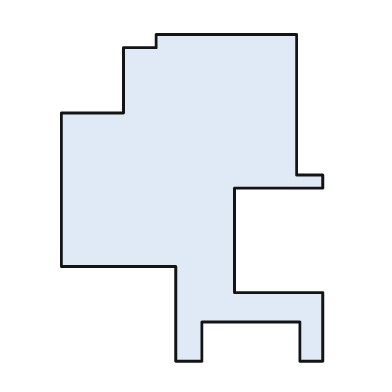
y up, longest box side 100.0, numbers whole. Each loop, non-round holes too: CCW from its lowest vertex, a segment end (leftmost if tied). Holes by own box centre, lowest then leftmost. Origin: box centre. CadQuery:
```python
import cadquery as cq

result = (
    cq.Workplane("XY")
    .moveTo(-5.0, -50.0)
    .lineTo(3.0, -50.0)
    .lineTo(3.0, -38.0)
    .lineTo(33.0, -38.0)
    .lineTo(33.0, -50.0)
    .lineTo(40.0, -50.0)
    .lineTo(40.0, -29.0)
    .lineTo(13.0, -29.0)
    .lineTo(13.0, 3.0)
    .lineTo(40.0, 3.0)
    .lineTo(40.0, 7.0)
    .lineTo(32.0, 7.0)
    .lineTo(32.0, 50.0)
    .lineTo(-11.0, 50.0)
    .lineTo(-11.0, 46.0)
    .lineTo(-21.0, 46.0)
    .lineTo(-21.0, 26.0)
    .lineTo(-40.0, 26.0)
    .lineTo(-40.0, -21.0)
    .lineTo(-5.0, -21.0)
    .close()
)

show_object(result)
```